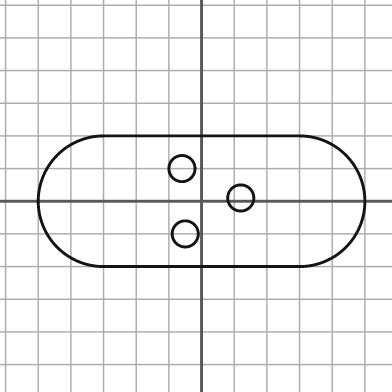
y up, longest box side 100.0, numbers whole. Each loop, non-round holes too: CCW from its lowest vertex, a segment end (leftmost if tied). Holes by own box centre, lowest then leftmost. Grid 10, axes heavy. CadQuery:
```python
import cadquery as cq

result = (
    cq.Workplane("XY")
    .moveTo(-30.0, -20.0)
    .lineTo(30.0, -20.0)
    .threePointArc((50.0, 0.0), (30.0, 20.0))
    .lineTo(-30.0, 20.0)
    .threePointArc((-50.0, 0.0), (-30.0, -20.0))
    .close()
    .moveTo(-5.0, -10.0)
    .circle(4.0)
    .moveTo(12.0, 1.0)
    .circle(4.0)
    .moveTo(-6.0, 10.0)
    .circle(4.0)
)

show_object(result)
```